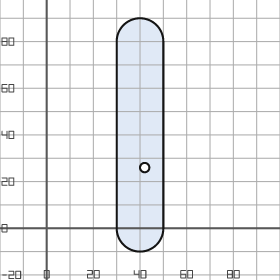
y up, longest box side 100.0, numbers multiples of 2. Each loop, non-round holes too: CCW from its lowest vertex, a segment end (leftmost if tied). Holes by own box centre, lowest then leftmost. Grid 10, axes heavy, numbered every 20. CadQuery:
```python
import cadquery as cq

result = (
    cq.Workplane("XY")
    .moveTo(30.0, 0.0)
    .threePointArc((40.0, -10.0), (50.0, 0.0))
    .lineTo(50.0, 80.0)
    .threePointArc((40.0, 90.0), (30.0, 80.0))
    .close()
    .moveTo(42.0, 26.0)
    .circle(2.0)
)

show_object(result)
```